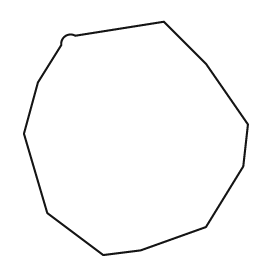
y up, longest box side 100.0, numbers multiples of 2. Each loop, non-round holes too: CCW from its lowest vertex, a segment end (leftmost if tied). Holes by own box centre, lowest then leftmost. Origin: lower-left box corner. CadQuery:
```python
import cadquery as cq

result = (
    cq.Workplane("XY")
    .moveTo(34.0, 0.0)
    .lineTo(50.0, 2.0)
    .lineTo(78.0, 12.0)
    .lineTo(94.0, 38.0)
    .lineTo(96.0, 56.0)
    .lineTo(78.0, 82.0)
    .lineTo(60.0, 100.0)
    .lineTo(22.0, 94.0)
    .threePointArc((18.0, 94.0), (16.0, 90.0))
    .lineTo(6.0, 74.0)
    .lineTo(0.0, 52.0)
    .lineTo(10.0, 18.0)
    .close()
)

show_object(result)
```